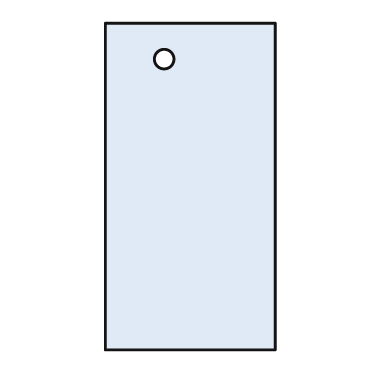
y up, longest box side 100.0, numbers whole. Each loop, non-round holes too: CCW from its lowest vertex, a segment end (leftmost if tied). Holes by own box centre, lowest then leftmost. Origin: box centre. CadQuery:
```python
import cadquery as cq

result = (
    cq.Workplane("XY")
    .moveTo(-26.0, -50.0)
    .lineTo(26.0, -50.0)
    .lineTo(26.0, 50.0)
    .lineTo(-26.0, 50.0)
    .close()
    .moveTo(-8.0, 39.0)
    .circle(3.0)
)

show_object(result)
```